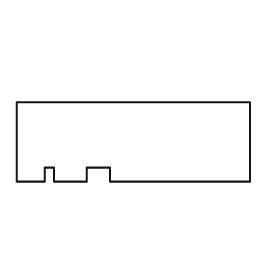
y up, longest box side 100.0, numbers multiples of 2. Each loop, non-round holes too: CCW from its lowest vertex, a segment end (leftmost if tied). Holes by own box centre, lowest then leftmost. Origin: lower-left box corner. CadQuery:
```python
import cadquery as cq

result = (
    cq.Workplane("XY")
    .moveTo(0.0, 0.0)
    .lineTo(12.0, 0.0)
    .lineTo(12.0, 6.0)
    .lineTo(16.0, 6.0)
    .lineTo(16.0, 0.0)
    .lineTo(30.0, 0.0)
    .lineTo(30.0, 6.0)
    .lineTo(40.0, 6.0)
    .lineTo(40.0, 0.0)
    .lineTo(100.0, 0.0)
    .lineTo(100.0, 34.0)
    .lineTo(0.0, 34.0)
    .close()
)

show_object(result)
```